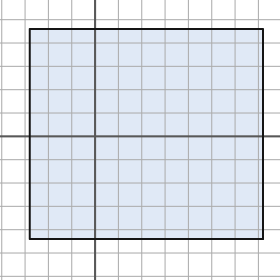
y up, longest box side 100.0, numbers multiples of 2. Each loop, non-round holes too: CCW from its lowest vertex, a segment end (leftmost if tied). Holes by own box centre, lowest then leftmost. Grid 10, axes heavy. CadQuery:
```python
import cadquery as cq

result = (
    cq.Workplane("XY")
    .moveTo(-28.0, -44.0)
    .lineTo(72.0, -44.0)
    .lineTo(72.0, 46.0)
    .lineTo(-28.0, 46.0)
    .close()
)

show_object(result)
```